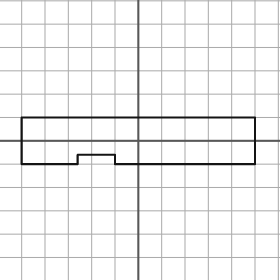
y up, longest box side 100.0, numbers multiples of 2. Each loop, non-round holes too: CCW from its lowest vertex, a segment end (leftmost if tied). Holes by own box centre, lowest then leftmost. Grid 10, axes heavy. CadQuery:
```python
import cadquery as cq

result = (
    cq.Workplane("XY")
    .moveTo(-50.0, -10.0)
    .lineTo(-26.0, -10.0)
    .lineTo(-26.0, -6.0)
    .lineTo(-10.0, -6.0)
    .lineTo(-10.0, -10.0)
    .lineTo(50.0, -10.0)
    .lineTo(50.0, 10.0)
    .lineTo(-50.0, 10.0)
    .close()
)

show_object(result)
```